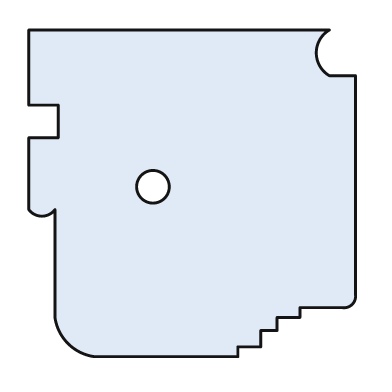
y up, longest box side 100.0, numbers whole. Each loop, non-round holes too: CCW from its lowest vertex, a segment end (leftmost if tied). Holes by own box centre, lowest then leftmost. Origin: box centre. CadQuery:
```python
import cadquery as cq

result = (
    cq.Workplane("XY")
    .moveTo(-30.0, -50.0)
    .lineTo(14.0, -50.0)
    .lineTo(14.0, -47.0)
    .lineTo(21.0, -47.0)
    .lineTo(21.0, -42.0)
    .lineTo(26.0, -42.0)
    .lineTo(26.0, -38.0)
    .lineTo(33.0, -38.0)
    .lineTo(33.0, -35.0)
    .lineTo(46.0, -35.0)
    .threePointArc((49.0, -34.0), (50.0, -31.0))
    .lineTo(50.0, 36.0)
    .lineTo(42.0, 36.0)
    .threePointArc((38.0, 43.0), (42.0, 50.0))
    .lineTo(-50.0, 50.0)
    .lineTo(-50.0, 27.0)
    .lineTo(-41.0, 27.0)
    .lineTo(-41.0, 17.0)
    .lineTo(-50.0, 17.0)
    .lineTo(-50.0, -5.0)
    .threePointArc((-46.0, -7.0), (-42.0, -5.0))
    .lineTo(-42.0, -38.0)
    .threePointArc((-38.0, -46.0), (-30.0, -50.0))
    .close()
    .moveTo(-12.0, 2.0)
    .circle(5.0)
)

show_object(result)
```